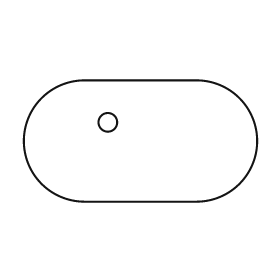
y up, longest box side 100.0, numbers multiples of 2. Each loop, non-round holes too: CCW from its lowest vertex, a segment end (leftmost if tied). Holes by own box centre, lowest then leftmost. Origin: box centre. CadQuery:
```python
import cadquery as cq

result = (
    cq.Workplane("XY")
    .moveTo(-24.0, -26.0)
    .lineTo(24.0, -26.0)
    .threePointArc((50.0, 0.0), (24.0, 26.0))
    .lineTo(-24.0, 26.0)
    .threePointArc((-50.0, 0.0), (-24.0, -26.0))
    .close()
    .moveTo(-14.0, 8.0)
    .circle(4.0)
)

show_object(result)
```